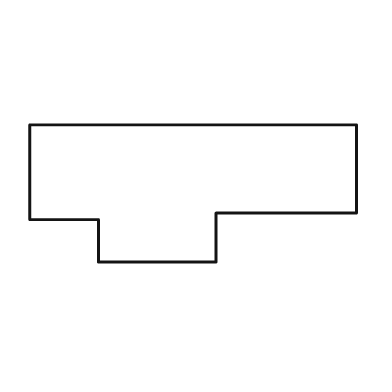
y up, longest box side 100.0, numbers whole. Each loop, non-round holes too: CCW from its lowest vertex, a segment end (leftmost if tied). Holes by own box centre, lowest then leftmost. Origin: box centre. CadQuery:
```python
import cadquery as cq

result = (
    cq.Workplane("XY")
    .moveTo(-29.0, -21.0)
    .lineTo(7.0, -21.0)
    .lineTo(7.0, -6.0)
    .lineTo(50.0, -6.0)
    .lineTo(50.0, 21.0)
    .lineTo(-50.0, 21.0)
    .lineTo(-50.0, -8.0)
    .lineTo(-29.0, -8.0)
    .close()
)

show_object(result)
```